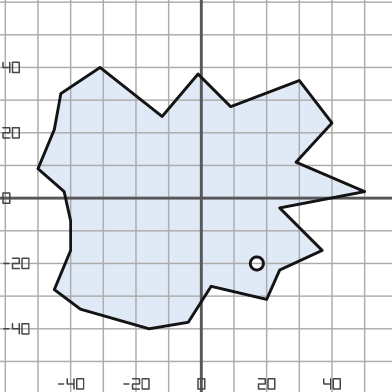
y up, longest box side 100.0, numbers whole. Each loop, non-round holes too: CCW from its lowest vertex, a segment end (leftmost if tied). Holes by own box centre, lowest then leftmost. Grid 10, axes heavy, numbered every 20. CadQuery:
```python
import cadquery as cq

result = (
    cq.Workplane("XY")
    .moveTo(-16.0, -40.0)
    .lineTo(-4.0, -38.0)
    .lineTo(3.0, -27.0)
    .lineTo(20.0, -31.0)
    .lineTo(24.0, -22.0)
    .lineTo(37.0, -16.0)
    .lineTo(24.0, -3.0)
    .lineTo(50.0, 2.0)
    .lineTo(29.0, 11.0)
    .lineTo(40.0, 23.0)
    .lineTo(30.0, 36.0)
    .lineTo(9.0, 28.0)
    .lineTo(-1.0, 38.0)
    .lineTo(-12.0, 25.0)
    .lineTo(-31.0, 40.0)
    .lineTo(-43.0, 32.0)
    .lineTo(-45.0, 21.0)
    .lineTo(-50.0, 9.0)
    .lineTo(-42.0, 2.0)
    .lineTo(-40.0, -7.0)
    .lineTo(-40.0, -16.0)
    .lineTo(-45.0, -28.0)
    .lineTo(-37.0, -34.0)
    .close()
    .moveTo(17.0, -20.0)
    .circle(2.0)
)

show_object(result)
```